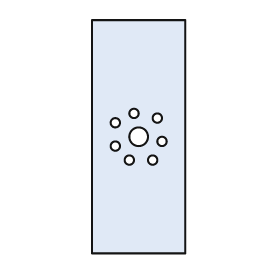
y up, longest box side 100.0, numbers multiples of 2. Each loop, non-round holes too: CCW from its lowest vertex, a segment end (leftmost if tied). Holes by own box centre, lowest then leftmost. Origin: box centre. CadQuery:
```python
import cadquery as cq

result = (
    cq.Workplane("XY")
    .moveTo(-20.0, -50.0)
    .lineTo(20.0, -50.0)
    .lineTo(20.0, 50.0)
    .lineTo(-20.0, 50.0)
    .close()
    .moveTo(-4.0, -10.0)
    .circle(2.0)
    .moveTo(6.0, -10.0)
    .circle(2.0)
    .moveTo(-10.0, -4.0)
    .circle(2.0)
    .moveTo(10.0, -2.0)
    .circle(2.0)
    .moveTo(0.0, 0.0)
    .circle(4.0)
    .moveTo(-10.0, 6.0)
    .circle(2.0)
    .moveTo(8.0, 8.0)
    .circle(2.0)
    .moveTo(-2.0, 10.0)
    .circle(2.0)
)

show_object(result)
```